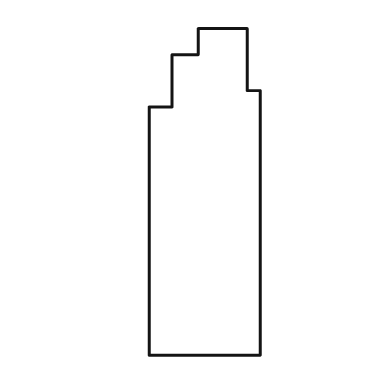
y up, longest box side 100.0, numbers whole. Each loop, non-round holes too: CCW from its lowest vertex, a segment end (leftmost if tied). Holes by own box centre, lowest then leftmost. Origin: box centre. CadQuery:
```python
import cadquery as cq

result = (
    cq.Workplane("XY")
    .moveTo(-17.0, -50.0)
    .lineTo(17.0, -50.0)
    .lineTo(17.0, 31.0)
    .lineTo(13.0, 31.0)
    .lineTo(13.0, 50.0)
    .lineTo(-2.0, 50.0)
    .lineTo(-2.0, 42.0)
    .lineTo(-10.0, 42.0)
    .lineTo(-10.0, 26.0)
    .lineTo(-17.0, 26.0)
    .close()
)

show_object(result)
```